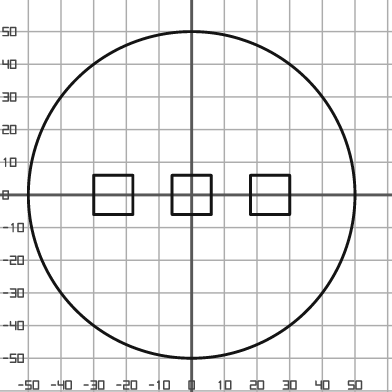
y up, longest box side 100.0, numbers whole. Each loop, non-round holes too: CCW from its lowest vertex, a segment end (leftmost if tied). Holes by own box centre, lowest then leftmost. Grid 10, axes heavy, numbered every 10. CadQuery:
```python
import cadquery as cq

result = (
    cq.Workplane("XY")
    .moveTo(0.0, 0.0)
    .circle(50.0)
    .moveTo(-30.0, -6.0)
    .lineTo(-18.0, -6.0)
    .lineTo(-18.0, 6.0)
    .lineTo(-30.0, 6.0)
    .close()
    .moveTo(-6.0, -6.0)
    .lineTo(6.0, -6.0)
    .lineTo(6.0, 6.0)
    .lineTo(-6.0, 6.0)
    .close()
    .moveTo(18.0, -6.0)
    .lineTo(30.0, -6.0)
    .lineTo(30.0, 6.0)
    .lineTo(18.0, 6.0)
    .close()
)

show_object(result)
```